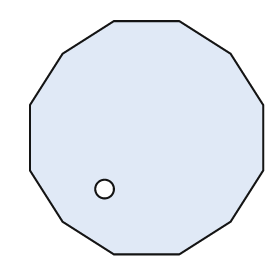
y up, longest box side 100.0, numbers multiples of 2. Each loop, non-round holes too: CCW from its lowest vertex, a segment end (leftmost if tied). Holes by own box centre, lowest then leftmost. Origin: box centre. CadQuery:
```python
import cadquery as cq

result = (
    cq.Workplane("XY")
    .moveTo(-14.0, -50.0)
    .lineTo(14.0, -50.0)
    .lineTo(36.0, -36.0)
    .lineTo(50.0, -14.0)
    .lineTo(50.0, 14.0)
    .lineTo(36.0, 36.0)
    .lineTo(14.0, 50.0)
    .lineTo(-14.0, 50.0)
    .lineTo(-36.0, 36.0)
    .lineTo(-50.0, 14.0)
    .lineTo(-50.0, -14.0)
    .lineTo(-36.0, -36.0)
    .close()
    .moveTo(-18.0, -22.0)
    .circle(4.0)
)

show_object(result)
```